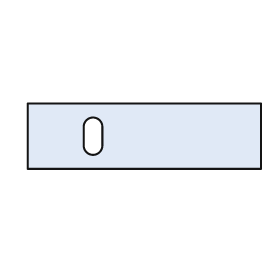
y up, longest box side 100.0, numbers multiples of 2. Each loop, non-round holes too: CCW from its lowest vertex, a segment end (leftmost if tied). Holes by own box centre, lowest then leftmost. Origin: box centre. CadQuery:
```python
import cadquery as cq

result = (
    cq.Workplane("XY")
    .moveTo(-50.0, -14.0)
    .lineTo(50.0, -14.0)
    .lineTo(50.0, 14.0)
    .lineTo(-50.0, 14.0)
    .close()
    .moveTo(-26.0, -4.0)
    .threePointArc((-22.0, -8.0), (-18.0, -4.0))
    .lineTo(-18.0, 4.0)
    .threePointArc((-22.0, 8.0), (-26.0, 4.0))
    .close()
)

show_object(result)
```